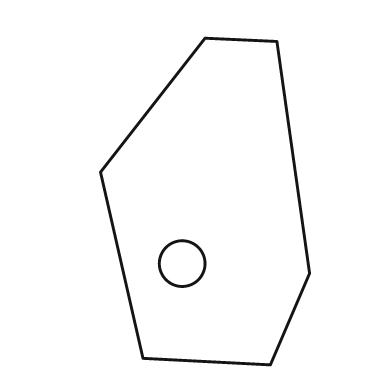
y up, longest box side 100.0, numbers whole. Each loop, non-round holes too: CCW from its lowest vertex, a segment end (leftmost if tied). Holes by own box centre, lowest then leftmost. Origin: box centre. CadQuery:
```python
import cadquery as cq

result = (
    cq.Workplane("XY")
    .moveTo(20.0, -50.0)
    .lineTo(32.0, -22.0)
    .lineTo(22.0, 49.0)
    .lineTo(0.0, 50.0)
    .lineTo(-32.0, 9.0)
    .lineTo(-19.0, -48.0)
    .close()
    .moveTo(-7.0, -19.0)
    .circle(7.0)
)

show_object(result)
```